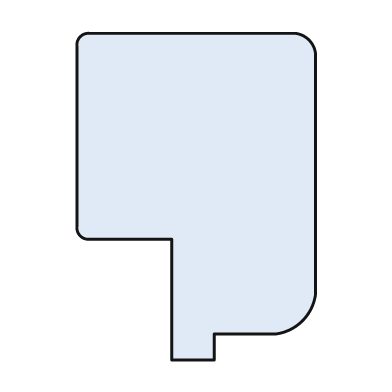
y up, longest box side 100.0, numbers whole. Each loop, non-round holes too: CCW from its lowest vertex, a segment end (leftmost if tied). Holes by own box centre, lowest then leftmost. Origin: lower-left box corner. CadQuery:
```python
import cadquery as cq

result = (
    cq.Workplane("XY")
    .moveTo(29.0, 0.0)
    .lineTo(42.0, 0.0)
    .lineTo(42.0, 8.0)
    .lineTo(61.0, 8.0)
    .threePointArc((69.0, 12.0), (73.0, 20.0))
    .lineTo(73.0, 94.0)
    .threePointArc((71.0, 98.0), (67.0, 100.0))
    .lineTo(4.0, 100.0)
    .threePointArc((1.0, 99.0), (0.0, 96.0))
    .lineTo(0.0, 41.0)
    .threePointArc((1.0, 38.0), (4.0, 37.0))
    .lineTo(29.0, 37.0)
    .close()
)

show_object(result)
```